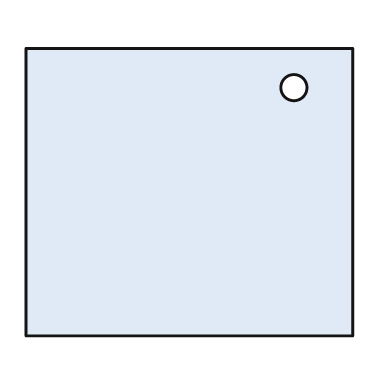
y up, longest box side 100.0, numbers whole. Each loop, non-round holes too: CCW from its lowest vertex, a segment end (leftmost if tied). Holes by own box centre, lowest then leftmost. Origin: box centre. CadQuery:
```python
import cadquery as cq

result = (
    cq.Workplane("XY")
    .moveTo(-50.0, -44.0)
    .lineTo(50.0, -44.0)
    .lineTo(50.0, 44.0)
    .lineTo(-50.0, 44.0)
    .close()
    .moveTo(32.0, 32.0)
    .circle(4.0)
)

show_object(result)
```